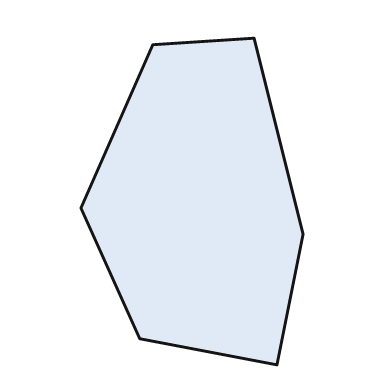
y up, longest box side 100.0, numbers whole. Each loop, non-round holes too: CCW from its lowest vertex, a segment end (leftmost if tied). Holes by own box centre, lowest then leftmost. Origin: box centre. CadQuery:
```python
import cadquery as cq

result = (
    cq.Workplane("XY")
    .moveTo(26.0, -50.0)
    .lineTo(34.0, -10.0)
    .lineTo(19.0, 50.0)
    .lineTo(-12.0, 48.0)
    .lineTo(-34.0, -2.0)
    .lineTo(-16.0, -42.0)
    .close()
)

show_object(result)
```